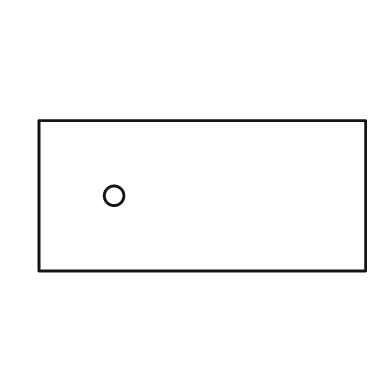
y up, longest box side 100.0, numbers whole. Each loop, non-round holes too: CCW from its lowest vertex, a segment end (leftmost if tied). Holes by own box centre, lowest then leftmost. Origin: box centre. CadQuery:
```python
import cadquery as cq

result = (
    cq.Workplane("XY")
    .moveTo(-50.0, -23.0)
    .lineTo(50.0, -23.0)
    .lineTo(50.0, 23.0)
    .lineTo(-50.0, 23.0)
    .close()
    .moveTo(-27.0, 0.0)
    .circle(3.0)
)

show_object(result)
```